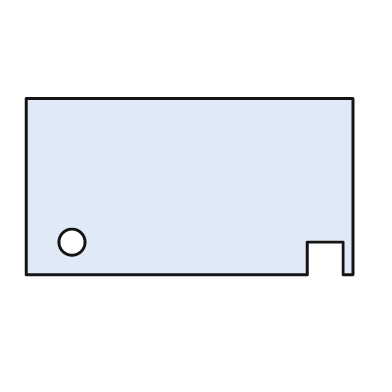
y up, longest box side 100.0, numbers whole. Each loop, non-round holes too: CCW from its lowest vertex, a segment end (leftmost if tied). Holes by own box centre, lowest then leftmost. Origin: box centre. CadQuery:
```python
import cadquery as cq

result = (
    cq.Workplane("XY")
    .moveTo(-50.0, -27.0)
    .lineTo(36.0, -27.0)
    .lineTo(36.0, -17.0)
    .lineTo(47.0, -17.0)
    .lineTo(47.0, -27.0)
    .lineTo(50.0, -27.0)
    .lineTo(50.0, 27.0)
    .lineTo(-50.0, 27.0)
    .close()
    .moveTo(-36.0, -17.0)
    .circle(4.0)
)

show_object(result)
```